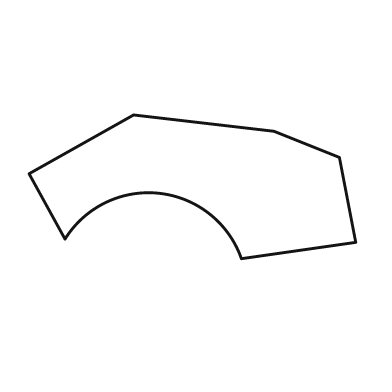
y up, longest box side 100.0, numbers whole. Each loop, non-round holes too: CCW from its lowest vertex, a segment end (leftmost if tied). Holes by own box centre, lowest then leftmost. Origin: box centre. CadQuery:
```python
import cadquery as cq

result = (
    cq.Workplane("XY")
    .moveTo(15.0, -22.0)
    .lineTo(50.0, -17.0)
    .lineTo(45.0, 9.0)
    .lineTo(25.0, 17.0)
    .lineTo(-18.0, 22.0)
    .lineTo(-50.0, 4.0)
    .lineTo(-39.0, -16.0)
    .threePointArc((-10.0, -2.0), (15.0, -22.0))
    .close()
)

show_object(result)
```